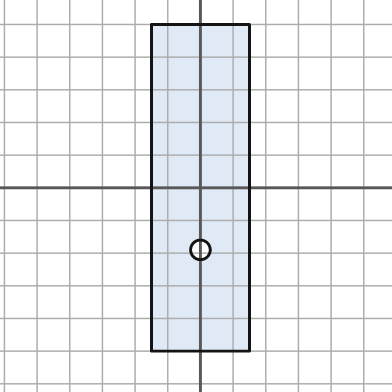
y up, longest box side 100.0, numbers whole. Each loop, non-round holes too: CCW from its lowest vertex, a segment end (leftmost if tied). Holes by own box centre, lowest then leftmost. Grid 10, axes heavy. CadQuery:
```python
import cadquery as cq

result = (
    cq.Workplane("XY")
    .moveTo(-15.0, -50.0)
    .lineTo(15.0, -50.0)
    .lineTo(15.0, 50.0)
    .lineTo(-15.0, 50.0)
    .close()
    .moveTo(0.0, -19.0)
    .circle(3.0)
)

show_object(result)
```